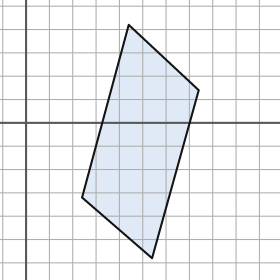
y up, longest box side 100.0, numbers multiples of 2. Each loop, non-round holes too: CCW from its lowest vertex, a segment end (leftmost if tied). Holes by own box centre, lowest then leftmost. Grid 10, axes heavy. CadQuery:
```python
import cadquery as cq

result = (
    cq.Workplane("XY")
    .moveTo(54.0, -58.0)
    .lineTo(74.0, 14.0)
    .lineTo(44.0, 42.0)
    .lineTo(24.0, -32.0)
    .close()
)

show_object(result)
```